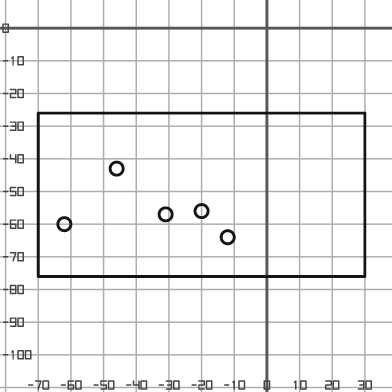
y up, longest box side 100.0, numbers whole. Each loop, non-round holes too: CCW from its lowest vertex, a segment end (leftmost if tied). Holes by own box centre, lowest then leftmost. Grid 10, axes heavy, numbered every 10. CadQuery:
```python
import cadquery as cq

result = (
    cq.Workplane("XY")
    .moveTo(-70.0, -76.0)
    .lineTo(30.0, -76.0)
    .lineTo(30.0, -26.0)
    .lineTo(-70.0, -26.0)
    .close()
    .moveTo(-12.0, -64.0)
    .circle(2.0)
    .moveTo(-62.0, -60.0)
    .circle(2.0)
    .moveTo(-31.0, -57.0)
    .circle(2.0)
    .moveTo(-20.0, -56.0)
    .circle(2.0)
    .moveTo(-46.0, -43.0)
    .circle(2.0)
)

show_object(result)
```